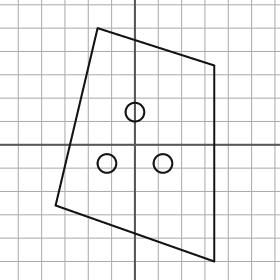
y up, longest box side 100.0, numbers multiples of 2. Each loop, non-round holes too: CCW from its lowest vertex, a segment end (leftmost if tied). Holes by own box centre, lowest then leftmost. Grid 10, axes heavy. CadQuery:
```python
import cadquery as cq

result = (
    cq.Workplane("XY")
    .moveTo(34.0, -50.0)
    .lineTo(34.0, 34.0)
    .lineTo(-16.0, 50.0)
    .lineTo(-34.0, -26.0)
    .close()
    .moveTo(-12.0, -8.0)
    .circle(4.0)
    .moveTo(12.0, -8.0)
    .circle(4.0)
    .moveTo(0.0, 14.0)
    .circle(4.0)
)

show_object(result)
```